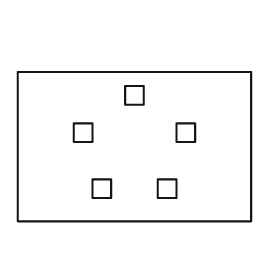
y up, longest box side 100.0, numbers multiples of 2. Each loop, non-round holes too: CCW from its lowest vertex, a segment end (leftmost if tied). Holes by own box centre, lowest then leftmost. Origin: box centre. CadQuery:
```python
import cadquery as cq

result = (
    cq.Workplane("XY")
    .moveTo(-50.0, -32.0)
    .lineTo(50.0, -32.0)
    .lineTo(50.0, 32.0)
    .lineTo(-50.0, 32.0)
    .close()
    .moveTo(-18.0, -22.0)
    .lineTo(-10.0, -22.0)
    .lineTo(-10.0, -14.0)
    .lineTo(-18.0, -14.0)
    .close()
    .moveTo(10.0, -22.0)
    .lineTo(18.0, -22.0)
    .lineTo(18.0, -14.0)
    .lineTo(10.0, -14.0)
    .close()
    .moveTo(-26.0, 2.0)
    .lineTo(-18.0, 2.0)
    .lineTo(-18.0, 10.0)
    .lineTo(-26.0, 10.0)
    .close()
    .moveTo(18.0, 2.0)
    .lineTo(26.0, 2.0)
    .lineTo(26.0, 10.0)
    .lineTo(18.0, 10.0)
    .close()
    .moveTo(-4.0, 18.0)
    .lineTo(4.0, 18.0)
    .lineTo(4.0, 26.0)
    .lineTo(-4.0, 26.0)
    .close()
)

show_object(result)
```